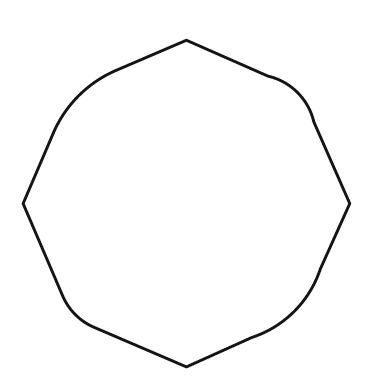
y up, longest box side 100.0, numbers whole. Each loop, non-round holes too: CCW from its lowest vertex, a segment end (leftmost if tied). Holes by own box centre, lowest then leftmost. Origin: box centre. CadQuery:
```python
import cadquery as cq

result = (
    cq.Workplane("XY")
    .moveTo(0.0, -50.0)
    .lineTo(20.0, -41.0)
    .threePointArc((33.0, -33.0), (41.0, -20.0))
    .lineTo(50.0, 0.0)
    .lineTo(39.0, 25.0)
    .threePointArc((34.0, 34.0), (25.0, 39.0))
    .lineTo(0.0, 50.0)
    .lineTo(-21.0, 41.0)
    .threePointArc((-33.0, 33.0), (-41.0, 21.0))
    .lineTo(-50.0, 0.0)
    .lineTo(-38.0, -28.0)
    .threePointArc((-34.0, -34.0), (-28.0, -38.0))
    .close()
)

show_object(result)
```